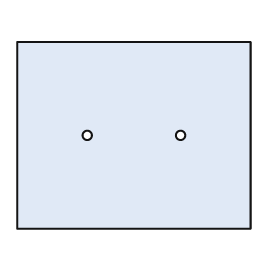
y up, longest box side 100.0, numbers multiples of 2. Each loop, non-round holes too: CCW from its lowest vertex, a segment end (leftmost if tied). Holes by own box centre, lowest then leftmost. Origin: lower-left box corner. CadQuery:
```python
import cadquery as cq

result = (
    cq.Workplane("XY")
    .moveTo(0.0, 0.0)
    .lineTo(100.0, 0.0)
    .lineTo(100.0, 80.0)
    .lineTo(0.0, 80.0)
    .close()
    .moveTo(30.0, 40.0)
    .circle(2.0)
    .moveTo(70.0, 40.0)
    .circle(2.0)
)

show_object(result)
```